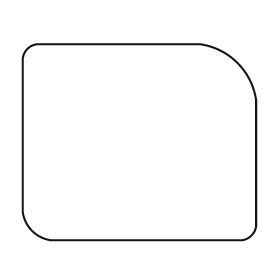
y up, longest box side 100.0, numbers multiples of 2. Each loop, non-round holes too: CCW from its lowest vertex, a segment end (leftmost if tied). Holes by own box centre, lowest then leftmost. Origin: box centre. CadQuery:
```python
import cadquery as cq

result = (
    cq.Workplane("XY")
    .moveTo(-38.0, -42.0)
    .lineTo(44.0, -42.0)
    .threePointArc((48.0, -40.0), (50.0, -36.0))
    .lineTo(50.0, 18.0)
    .threePointArc((42.0, 34.0), (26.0, 42.0))
    .lineTo(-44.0, 42.0)
    .threePointArc((-48.0, 40.0), (-50.0, 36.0))
    .lineTo(-50.0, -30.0)
    .threePointArc((-46.0, -38.0), (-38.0, -42.0))
    .close()
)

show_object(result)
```